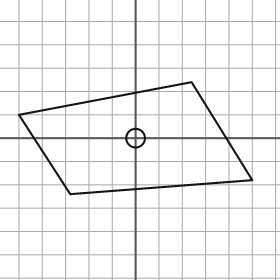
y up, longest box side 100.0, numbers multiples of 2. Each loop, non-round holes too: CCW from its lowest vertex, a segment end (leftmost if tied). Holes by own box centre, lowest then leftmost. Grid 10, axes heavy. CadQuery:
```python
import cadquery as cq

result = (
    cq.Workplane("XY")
    .moveTo(-28.0, -24.0)
    .lineTo(50.0, -18.0)
    .lineTo(24.0, 24.0)
    .lineTo(-50.0, 10.0)
    .close()
    .moveTo(0.0, 0.0)
    .circle(4.0)
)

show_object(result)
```